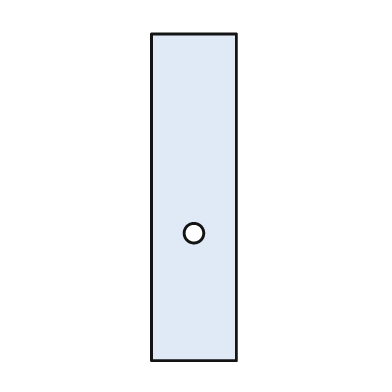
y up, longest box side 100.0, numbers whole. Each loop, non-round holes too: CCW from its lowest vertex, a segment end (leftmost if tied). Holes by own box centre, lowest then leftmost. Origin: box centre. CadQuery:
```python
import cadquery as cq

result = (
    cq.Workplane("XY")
    .moveTo(-13.0, -50.0)
    .lineTo(13.0, -50.0)
    .lineTo(13.0, 50.0)
    .lineTo(-13.0, 50.0)
    .close()
    .moveTo(0.0, -11.0)
    .circle(3.0)
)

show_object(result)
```